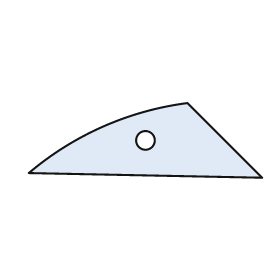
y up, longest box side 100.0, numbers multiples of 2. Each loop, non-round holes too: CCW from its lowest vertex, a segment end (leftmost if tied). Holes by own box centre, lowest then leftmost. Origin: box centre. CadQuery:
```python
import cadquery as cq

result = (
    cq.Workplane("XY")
    .moveTo(50.0, -16.0)
    .lineTo(18.0, 16.0)
    .threePointArc((-18.0, 6.0), (-50.0, -14.0))
    .close()
    .moveTo(0.0, 0.0)
    .circle(4.0)
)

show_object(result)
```